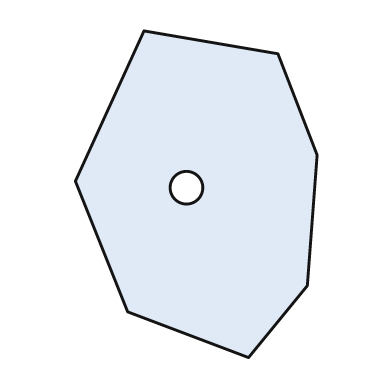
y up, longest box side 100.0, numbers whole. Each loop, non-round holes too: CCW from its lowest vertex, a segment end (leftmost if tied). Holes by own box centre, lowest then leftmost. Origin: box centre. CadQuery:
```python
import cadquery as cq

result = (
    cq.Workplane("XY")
    .moveTo(16.0, -50.0)
    .lineTo(34.0, -28.0)
    .lineTo(37.0, 12.0)
    .lineTo(25.0, 43.0)
    .lineTo(-16.0, 50.0)
    .lineTo(-37.0, 4.0)
    .lineTo(-21.0, -36.0)
    .close()
    .moveTo(-3.0, 2.0)
    .circle(5.0)
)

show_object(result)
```